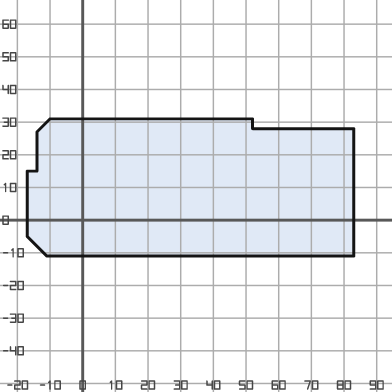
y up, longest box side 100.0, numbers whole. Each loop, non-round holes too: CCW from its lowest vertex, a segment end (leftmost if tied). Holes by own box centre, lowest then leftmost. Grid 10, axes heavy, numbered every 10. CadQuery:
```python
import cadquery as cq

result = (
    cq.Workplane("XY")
    .moveTo(-11.0, -11.0)
    .lineTo(83.0, -11.0)
    .lineTo(83.0, 28.0)
    .lineTo(52.0, 28.0)
    .lineTo(52.0, 31.0)
    .lineTo(-10.0, 31.0)
    .lineTo(-14.0, 27.0)
    .lineTo(-14.0, 15.0)
    .lineTo(-17.0, 15.0)
    .lineTo(-17.0, -5.0)
    .close()
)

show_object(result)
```